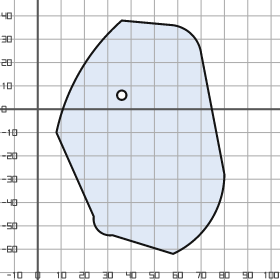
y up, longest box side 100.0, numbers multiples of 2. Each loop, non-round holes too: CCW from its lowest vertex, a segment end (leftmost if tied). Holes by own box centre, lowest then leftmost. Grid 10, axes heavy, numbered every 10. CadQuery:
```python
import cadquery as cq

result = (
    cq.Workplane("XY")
    .moveTo(58.0, -62.0)
    .threePointArc((74.0, -48.0), (80.0, -28.0))
    .lineTo(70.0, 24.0)
    .threePointArc((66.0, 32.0), (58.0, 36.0))
    .lineTo(36.0, 38.0)
    .threePointArc((18.0, 16.0), (8.0, -10.0))
    .lineTo(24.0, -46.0)
    .threePointArc((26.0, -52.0), (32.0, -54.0))
    .close()
    .moveTo(36.0, 6.0)
    .circle(2.0)
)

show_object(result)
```